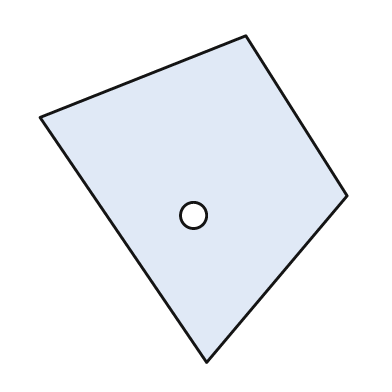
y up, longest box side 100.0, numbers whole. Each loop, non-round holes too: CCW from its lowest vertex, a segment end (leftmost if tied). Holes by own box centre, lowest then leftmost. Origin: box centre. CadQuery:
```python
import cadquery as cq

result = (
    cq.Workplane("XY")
    .moveTo(4.0, -50.0)
    .lineTo(47.0, 1.0)
    .lineTo(16.0, 50.0)
    .lineTo(-47.0, 25.0)
    .close()
    .moveTo(0.0, -5.0)
    .circle(4.0)
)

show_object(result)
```